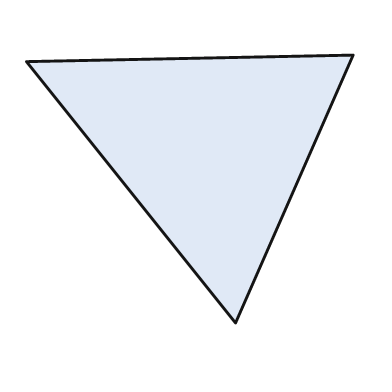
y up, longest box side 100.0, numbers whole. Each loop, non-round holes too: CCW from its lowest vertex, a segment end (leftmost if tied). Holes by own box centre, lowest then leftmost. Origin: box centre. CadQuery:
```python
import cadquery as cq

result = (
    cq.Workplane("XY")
    .moveTo(14.0, -41.0)
    .lineTo(50.0, 41.0)
    .lineTo(-50.0, 39.0)
    .close()
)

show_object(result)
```